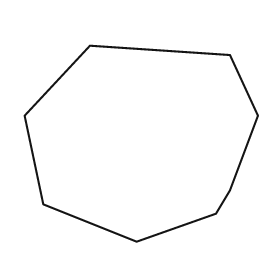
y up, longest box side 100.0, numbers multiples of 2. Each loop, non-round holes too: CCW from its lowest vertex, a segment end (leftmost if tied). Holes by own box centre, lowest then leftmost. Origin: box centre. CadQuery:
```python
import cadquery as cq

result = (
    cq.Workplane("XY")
    .moveTo(-2.0, -42.0)
    .lineTo(32.0, -30.0)
    .lineTo(38.0, -20.0)
    .lineTo(50.0, 12.0)
    .lineTo(38.0, 38.0)
    .lineTo(-22.0, 42.0)
    .lineTo(-50.0, 12.0)
    .lineTo(-42.0, -26.0)
    .close()
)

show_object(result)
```